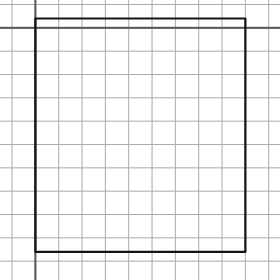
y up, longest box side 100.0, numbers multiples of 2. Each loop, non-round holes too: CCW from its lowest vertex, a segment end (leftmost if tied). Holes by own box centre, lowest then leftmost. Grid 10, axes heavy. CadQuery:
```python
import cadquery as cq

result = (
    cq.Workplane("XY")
    .moveTo(0.0, -96.0)
    .lineTo(90.0, -96.0)
    .lineTo(90.0, 4.0)
    .lineTo(0.0, 4.0)
    .close()
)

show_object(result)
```